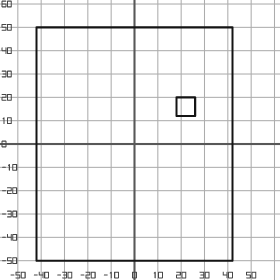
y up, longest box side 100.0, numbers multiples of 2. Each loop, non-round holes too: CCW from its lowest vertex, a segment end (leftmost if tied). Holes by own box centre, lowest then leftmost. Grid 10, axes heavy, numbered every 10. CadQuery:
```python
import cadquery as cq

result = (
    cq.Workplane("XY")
    .moveTo(-42.0, -50.0)
    .lineTo(42.0, -50.0)
    .lineTo(42.0, 50.0)
    .lineTo(-42.0, 50.0)
    .close()
    .moveTo(18.0, 12.0)
    .lineTo(26.0, 12.0)
    .lineTo(26.0, 20.0)
    .lineTo(18.0, 20.0)
    .close()
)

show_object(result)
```